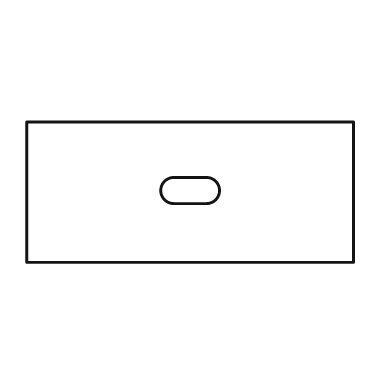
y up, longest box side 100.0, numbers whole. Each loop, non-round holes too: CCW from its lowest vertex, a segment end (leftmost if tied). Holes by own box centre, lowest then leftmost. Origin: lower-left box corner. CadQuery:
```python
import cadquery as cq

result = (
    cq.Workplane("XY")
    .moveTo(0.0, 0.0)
    .lineTo(100.0, 0.0)
    .lineTo(100.0, 43.0)
    .lineTo(0.0, 43.0)
    .close()
    .moveTo(45.0, 18.0)
    .lineTo(55.0, 18.0)
    .threePointArc((59.0, 22.0), (55.0, 26.0))
    .lineTo(45.0, 26.0)
    .threePointArc((41.0, 22.0), (45.0, 18.0))
    .close()
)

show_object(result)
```